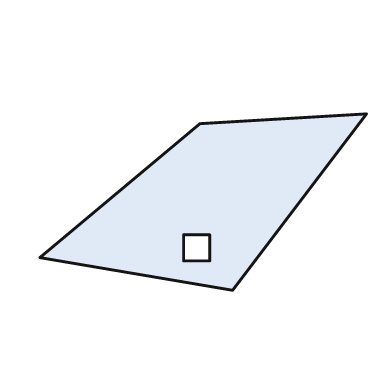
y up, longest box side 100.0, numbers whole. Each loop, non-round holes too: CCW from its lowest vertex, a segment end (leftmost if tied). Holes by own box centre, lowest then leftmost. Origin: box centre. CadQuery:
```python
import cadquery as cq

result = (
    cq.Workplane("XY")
    .moveTo(9.0, -27.0)
    .lineTo(50.0, 27.0)
    .lineTo(-1.0, 24.0)
    .lineTo(-50.0, -17.0)
    .close()
    .moveTo(-6.0, -18.0)
    .lineTo(2.0, -18.0)
    .lineTo(2.0, -10.0)
    .lineTo(-6.0, -10.0)
    .close()
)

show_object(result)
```